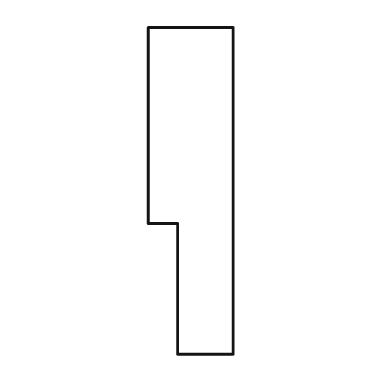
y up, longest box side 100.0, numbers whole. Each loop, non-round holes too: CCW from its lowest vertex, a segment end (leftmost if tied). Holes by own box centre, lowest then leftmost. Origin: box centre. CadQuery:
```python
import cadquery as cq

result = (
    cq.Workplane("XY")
    .moveTo(-4.0, -50.0)
    .lineTo(13.0, -50.0)
    .lineTo(13.0, 50.0)
    .lineTo(-13.0, 50.0)
    .lineTo(-13.0, -10.0)
    .lineTo(-4.0, -10.0)
    .close()
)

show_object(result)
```